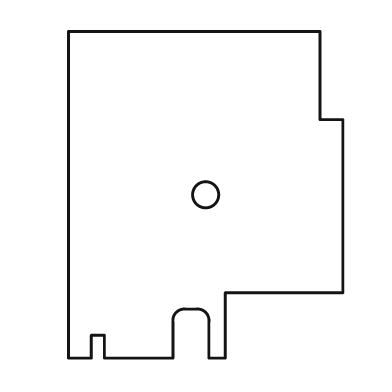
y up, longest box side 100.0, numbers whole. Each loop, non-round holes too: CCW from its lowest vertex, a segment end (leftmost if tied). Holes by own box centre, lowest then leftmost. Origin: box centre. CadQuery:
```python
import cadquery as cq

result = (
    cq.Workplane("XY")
    .moveTo(-42.0, -50.0)
    .lineTo(-35.0, -50.0)
    .lineTo(-35.0, -43.0)
    .lineTo(-31.0, -43.0)
    .lineTo(-31.0, -50.0)
    .lineTo(-10.0, -50.0)
    .lineTo(-10.0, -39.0)
    .threePointArc((-9.0, -36.0), (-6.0, -35.0))
    .lineTo(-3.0, -35.0)
    .threePointArc((0.0, -36.0), (1.0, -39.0))
    .lineTo(1.0, -50.0)
    .lineTo(6.0, -50.0)
    .lineTo(6.0, -30.0)
    .lineTo(42.0, -30.0)
    .lineTo(42.0, 23.0)
    .lineTo(35.0, 23.0)
    .lineTo(35.0, 50.0)
    .lineTo(-42.0, 50.0)
    .close()
    .moveTo(0.0, 0.0)
    .circle(4.0)
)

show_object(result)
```